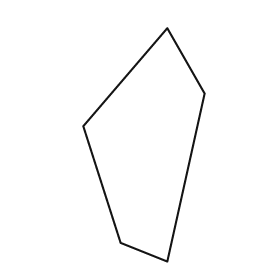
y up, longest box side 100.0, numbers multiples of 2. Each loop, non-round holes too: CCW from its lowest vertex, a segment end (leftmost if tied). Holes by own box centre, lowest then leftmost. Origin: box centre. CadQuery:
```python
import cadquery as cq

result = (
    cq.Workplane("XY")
    .moveTo(10.0, -50.0)
    .lineTo(26.0, 22.0)
    .lineTo(10.0, 50.0)
    .lineTo(-26.0, 8.0)
    .lineTo(-10.0, -42.0)
    .close()
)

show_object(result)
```